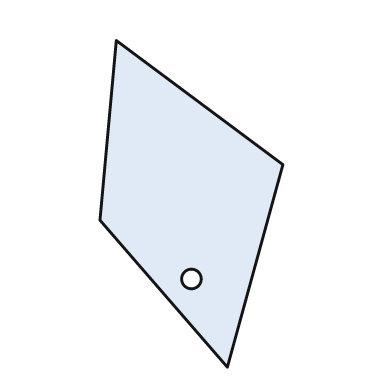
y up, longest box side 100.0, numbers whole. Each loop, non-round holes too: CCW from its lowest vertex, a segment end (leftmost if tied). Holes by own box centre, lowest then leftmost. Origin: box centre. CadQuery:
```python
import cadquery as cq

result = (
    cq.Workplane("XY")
    .moveTo(11.0, -50.0)
    .lineTo(28.0, 12.0)
    .lineTo(-23.0, 50.0)
    .lineTo(-28.0, -5.0)
    .close()
    .moveTo(0.0, -23.0)
    .circle(3.0)
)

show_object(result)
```